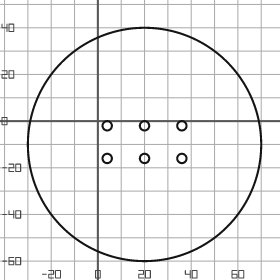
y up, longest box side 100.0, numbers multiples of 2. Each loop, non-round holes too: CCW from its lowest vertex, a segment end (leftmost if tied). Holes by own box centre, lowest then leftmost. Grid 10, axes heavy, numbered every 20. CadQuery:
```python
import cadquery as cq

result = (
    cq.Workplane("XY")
    .moveTo(20.0, -10.0)
    .circle(50.0)
    .moveTo(4.0, -16.0)
    .circle(2.0)
    .moveTo(20.0, -16.0)
    .circle(2.0)
    .moveTo(36.0, -16.0)
    .circle(2.0)
    .moveTo(4.0, -2.0)
    .circle(2.0)
    .moveTo(20.0, -2.0)
    .circle(2.0)
    .moveTo(36.0, -2.0)
    .circle(2.0)
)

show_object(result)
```